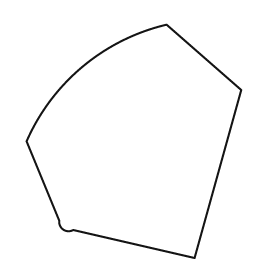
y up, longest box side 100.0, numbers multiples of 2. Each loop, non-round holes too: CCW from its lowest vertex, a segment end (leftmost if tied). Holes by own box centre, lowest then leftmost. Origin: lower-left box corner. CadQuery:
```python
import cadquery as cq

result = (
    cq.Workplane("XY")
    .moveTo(72.0, 0.0)
    .lineTo(92.0, 72.0)
    .lineTo(60.0, 100.0)
    .threePointArc((24.0, 82.0), (0.0, 50.0))
    .lineTo(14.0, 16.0)
    .threePointArc((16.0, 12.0), (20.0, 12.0))
    .close()
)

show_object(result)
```